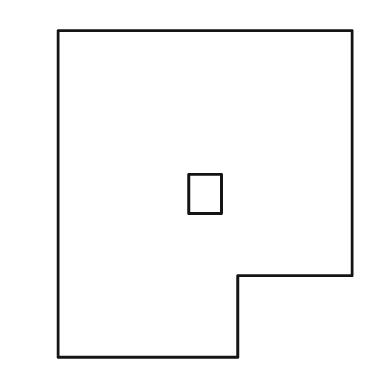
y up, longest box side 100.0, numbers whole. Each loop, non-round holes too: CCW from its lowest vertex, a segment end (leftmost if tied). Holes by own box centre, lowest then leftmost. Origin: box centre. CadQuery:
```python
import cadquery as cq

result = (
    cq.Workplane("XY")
    .moveTo(-45.0, -50.0)
    .lineTo(10.0, -50.0)
    .lineTo(10.0, -25.0)
    .lineTo(45.0, -25.0)
    .lineTo(45.0, 50.0)
    .lineTo(-45.0, 50.0)
    .close()
    .moveTo(-5.0, -6.0)
    .lineTo(5.0, -6.0)
    .lineTo(5.0, 6.0)
    .lineTo(-5.0, 6.0)
    .close()
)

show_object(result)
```